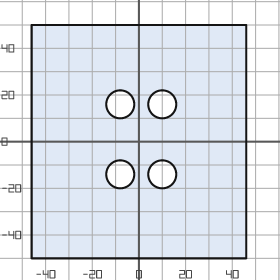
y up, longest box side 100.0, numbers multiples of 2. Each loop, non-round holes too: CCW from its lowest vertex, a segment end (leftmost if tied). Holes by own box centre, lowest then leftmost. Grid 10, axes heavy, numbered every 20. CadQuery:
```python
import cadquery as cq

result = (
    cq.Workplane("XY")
    .moveTo(-46.0, -50.0)
    .lineTo(46.0, -50.0)
    .lineTo(46.0, 50.0)
    .lineTo(-46.0, 50.0)
    .close()
    .moveTo(-8.0, -14.0)
    .circle(6.0)
    .moveTo(10.0, -14.0)
    .circle(6.0)
    .moveTo(-8.0, 16.0)
    .circle(6.0)
    .moveTo(10.0, 16.0)
    .circle(6.0)
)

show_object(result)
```